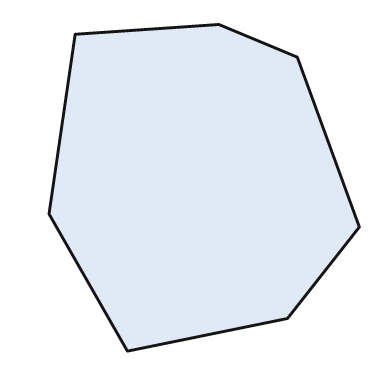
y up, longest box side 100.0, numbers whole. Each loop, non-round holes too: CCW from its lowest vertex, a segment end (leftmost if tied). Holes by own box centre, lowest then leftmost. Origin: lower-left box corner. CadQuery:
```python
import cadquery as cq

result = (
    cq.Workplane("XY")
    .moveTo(24.0, 0.0)
    .lineTo(73.0, 10.0)
    .lineTo(95.0, 38.0)
    .lineTo(76.0, 90.0)
    .lineTo(52.0, 100.0)
    .lineTo(8.0, 97.0)
    .lineTo(0.0, 42.0)
    .close()
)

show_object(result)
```